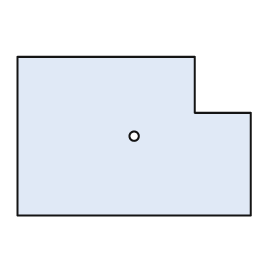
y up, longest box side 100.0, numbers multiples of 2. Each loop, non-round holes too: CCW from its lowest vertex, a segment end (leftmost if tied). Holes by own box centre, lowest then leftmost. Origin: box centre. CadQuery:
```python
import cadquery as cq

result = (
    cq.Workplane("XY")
    .moveTo(-50.0, -34.0)
    .lineTo(50.0, -34.0)
    .lineTo(50.0, 10.0)
    .lineTo(26.0, 10.0)
    .lineTo(26.0, 34.0)
    .lineTo(-50.0, 34.0)
    .close()
    .moveTo(0.0, 0.0)
    .circle(2.0)
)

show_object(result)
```